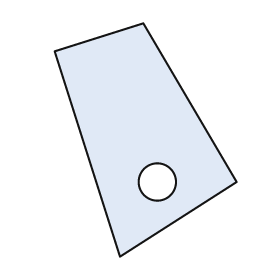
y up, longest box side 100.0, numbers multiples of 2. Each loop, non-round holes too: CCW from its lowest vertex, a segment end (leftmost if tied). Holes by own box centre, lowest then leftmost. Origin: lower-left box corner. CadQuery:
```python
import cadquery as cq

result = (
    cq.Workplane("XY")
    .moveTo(28.0, 0.0)
    .lineTo(78.0, 32.0)
    .lineTo(38.0, 100.0)
    .lineTo(0.0, 88.0)
    .close()
    .moveTo(44.0, 32.0)
    .circle(8.0)
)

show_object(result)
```